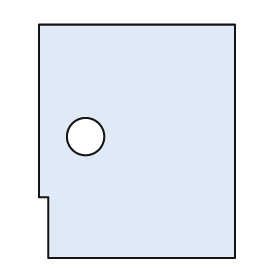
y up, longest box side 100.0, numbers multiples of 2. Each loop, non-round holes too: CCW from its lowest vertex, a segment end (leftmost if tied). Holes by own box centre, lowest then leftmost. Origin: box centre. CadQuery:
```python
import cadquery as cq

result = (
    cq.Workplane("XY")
    .moveTo(-38.0, -50.0)
    .lineTo(42.0, -50.0)
    .lineTo(42.0, 50.0)
    .lineTo(-42.0, 50.0)
    .lineTo(-42.0, -24.0)
    .lineTo(-38.0, -24.0)
    .close()
    .moveTo(-22.0, 2.0)
    .circle(8.0)
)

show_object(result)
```